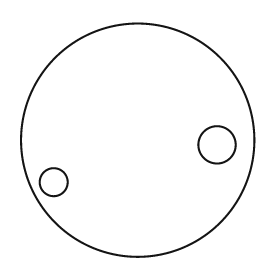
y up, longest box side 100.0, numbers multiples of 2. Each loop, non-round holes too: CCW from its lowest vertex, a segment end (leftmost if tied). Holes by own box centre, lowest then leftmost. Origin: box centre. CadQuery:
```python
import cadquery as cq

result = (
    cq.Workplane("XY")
    .moveTo(0.0, 0.0)
    .circle(50.0)
    .moveTo(-36.0, -18.0)
    .circle(6.0)
    .moveTo(34.0, -2.0)
    .circle(8.0)
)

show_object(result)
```